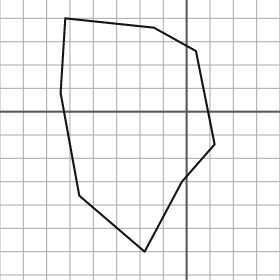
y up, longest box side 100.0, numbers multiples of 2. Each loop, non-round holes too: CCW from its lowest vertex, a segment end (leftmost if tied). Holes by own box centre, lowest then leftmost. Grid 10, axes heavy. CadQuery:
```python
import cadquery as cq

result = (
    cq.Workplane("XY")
    .moveTo(-18.0, -60.0)
    .lineTo(-2.0, -30.0)
    .lineTo(12.0, -14.0)
    .lineTo(4.0, 26.0)
    .lineTo(-14.0, 36.0)
    .lineTo(-52.0, 40.0)
    .lineTo(-54.0, 8.0)
    .lineTo(-46.0, -36.0)
    .close()
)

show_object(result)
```